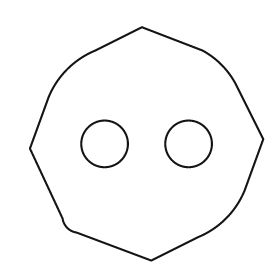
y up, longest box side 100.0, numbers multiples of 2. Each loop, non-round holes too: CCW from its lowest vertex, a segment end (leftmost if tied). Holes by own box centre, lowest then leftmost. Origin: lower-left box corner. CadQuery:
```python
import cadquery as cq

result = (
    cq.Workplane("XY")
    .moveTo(52.0, 0.0)
    .lineTo(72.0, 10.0)
    .threePointArc((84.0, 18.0), (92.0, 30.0))
    .lineTo(100.0, 52.0)
    .lineTo(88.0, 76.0)
    .threePointArc((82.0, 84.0), (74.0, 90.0))
    .lineTo(48.0, 100.0)
    .lineTo(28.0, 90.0)
    .threePointArc((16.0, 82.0), (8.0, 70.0))
    .lineTo(0.0, 48.0)
    .lineTo(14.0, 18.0)
    .threePointArc((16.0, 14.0), (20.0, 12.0))
    .close()
    .moveTo(32.0, 50.0)
    .circle(10.0)
    .moveTo(68.0, 50.0)
    .circle(10.0)
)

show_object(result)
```